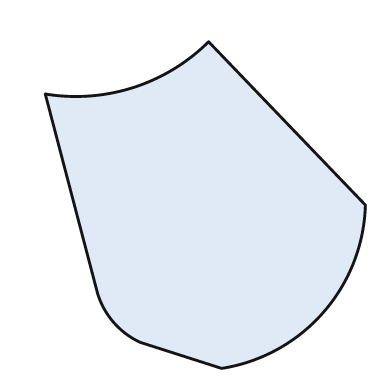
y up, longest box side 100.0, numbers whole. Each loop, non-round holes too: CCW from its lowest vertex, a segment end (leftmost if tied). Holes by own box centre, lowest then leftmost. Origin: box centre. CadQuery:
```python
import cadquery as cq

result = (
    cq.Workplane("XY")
    .moveTo(5.0, -50.0)
    .threePointArc((36.0, -33.0), (49.0, 0.0))
    .lineTo(1.0, 50.0)
    .threePointArc((-22.0, 36.0), (-49.0, 34.0))
    .lineTo(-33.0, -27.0)
    .threePointArc((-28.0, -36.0), (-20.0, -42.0))
    .close()
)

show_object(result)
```